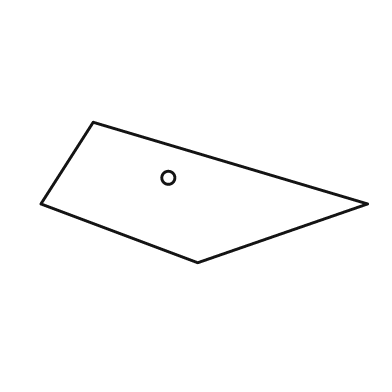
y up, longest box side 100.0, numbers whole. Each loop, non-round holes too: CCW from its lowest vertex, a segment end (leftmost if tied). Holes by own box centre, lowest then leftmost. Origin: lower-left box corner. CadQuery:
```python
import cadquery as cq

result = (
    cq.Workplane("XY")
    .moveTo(48.0, 0.0)
    .lineTo(100.0, 18.0)
    .lineTo(16.0, 43.0)
    .lineTo(0.0, 18.0)
    .close()
    .moveTo(39.0, 26.0)
    .circle(2.0)
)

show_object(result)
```